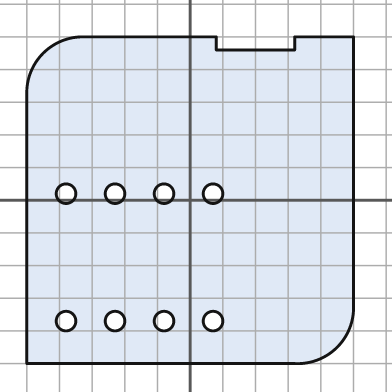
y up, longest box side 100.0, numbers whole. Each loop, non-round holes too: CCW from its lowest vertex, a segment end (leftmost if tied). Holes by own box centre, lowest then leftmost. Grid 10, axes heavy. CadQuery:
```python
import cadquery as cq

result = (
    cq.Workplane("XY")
    .moveTo(-50.0, -50.0)
    .lineTo(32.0, -50.0)
    .threePointArc((45.0, -45.0), (50.0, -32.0))
    .lineTo(50.0, 50.0)
    .lineTo(32.0, 50.0)
    .lineTo(32.0, 46.0)
    .lineTo(8.0, 46.0)
    .lineTo(8.0, 50.0)
    .lineTo(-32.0, 50.0)
    .threePointArc((-45.0, 45.0), (-50.0, 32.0))
    .close()
    .moveTo(-38.0, -37.0)
    .circle(3.0)
    .moveTo(-23.0, -37.0)
    .circle(3.0)
    .moveTo(-8.0, -37.0)
    .circle(3.0)
    .moveTo(7.0, -37.0)
    .circle(3.0)
    .moveTo(-38.0, 2.0)
    .circle(3.0)
    .moveTo(-23.0, 2.0)
    .circle(3.0)
    .moveTo(-8.0, 2.0)
    .circle(3.0)
    .moveTo(7.0, 2.0)
    .circle(3.0)
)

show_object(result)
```